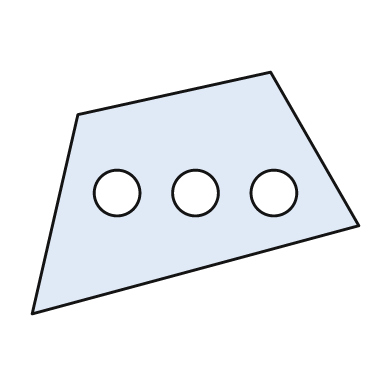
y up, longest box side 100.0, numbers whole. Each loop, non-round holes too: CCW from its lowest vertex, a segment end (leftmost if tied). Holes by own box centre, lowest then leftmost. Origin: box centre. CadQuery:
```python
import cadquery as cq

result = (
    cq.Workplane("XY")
    .moveTo(-50.0, -37.0)
    .lineTo(50.0, -10.0)
    .lineTo(23.0, 37.0)
    .lineTo(-36.0, 24.0)
    .close()
    .moveTo(-24.0, 0.0)
    .circle(7.0)
    .moveTo(0.0, 0.0)
    .circle(7.0)
    .moveTo(24.0, 0.0)
    .circle(7.0)
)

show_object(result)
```